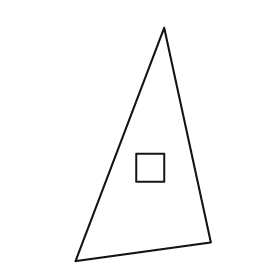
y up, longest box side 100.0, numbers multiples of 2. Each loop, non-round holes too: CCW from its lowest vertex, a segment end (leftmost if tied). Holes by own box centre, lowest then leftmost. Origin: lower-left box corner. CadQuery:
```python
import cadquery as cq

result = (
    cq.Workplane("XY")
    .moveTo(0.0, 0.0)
    .lineTo(58.0, 8.0)
    .lineTo(38.0, 100.0)
    .close()
    .moveTo(26.0, 34.0)
    .lineTo(38.0, 34.0)
    .lineTo(38.0, 46.0)
    .lineTo(26.0, 46.0)
    .close()
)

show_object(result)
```